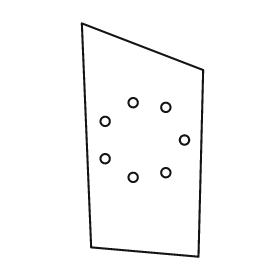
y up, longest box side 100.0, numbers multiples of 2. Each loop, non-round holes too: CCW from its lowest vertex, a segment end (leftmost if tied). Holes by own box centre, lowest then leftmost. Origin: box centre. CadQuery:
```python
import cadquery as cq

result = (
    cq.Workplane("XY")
    .moveTo(24.0, -50.0)
    .lineTo(26.0, 30.0)
    .lineTo(-26.0, 50.0)
    .lineTo(-22.0, -46.0)
    .close()
    .moveTo(-4.0, -16.0)
    .circle(2.0)
    .moveTo(10.0, -14.0)
    .circle(2.0)
    .moveTo(-16.0, -8.0)
    .circle(2.0)
    .moveTo(18.0, 0.0)
    .circle(2.0)
    .moveTo(-16.0, 8.0)
    .circle(2.0)
    .moveTo(10.0, 14.0)
    .circle(2.0)
    .moveTo(-4.0, 16.0)
    .circle(2.0)
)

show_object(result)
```